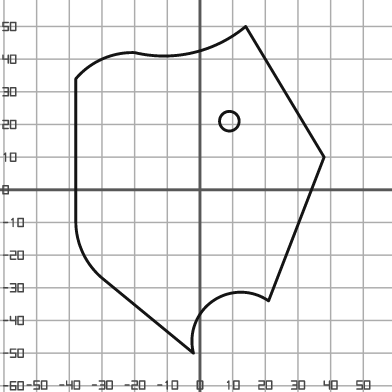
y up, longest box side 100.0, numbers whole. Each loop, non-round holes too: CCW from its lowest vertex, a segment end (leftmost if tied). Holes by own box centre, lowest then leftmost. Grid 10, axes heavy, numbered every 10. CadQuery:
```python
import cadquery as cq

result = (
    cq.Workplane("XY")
    .moveTo(-2.0, -50.0)
    .threePointArc((4.0, -34.0), (21.0, -34.0))
    .lineTo(38.0, 10.0)
    .lineTo(14.0, 50.0)
    .threePointArc((-2.0, 42.0), (-20.0, 42.0))
    .threePointArc((-30.0, 40.0), (-38.0, 34.0))
    .lineTo(-38.0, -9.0)
    .threePointArc((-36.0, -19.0), (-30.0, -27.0))
    .close()
    .moveTo(9.0, 21.0)
    .circle(3.0)
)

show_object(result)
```